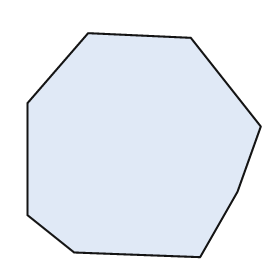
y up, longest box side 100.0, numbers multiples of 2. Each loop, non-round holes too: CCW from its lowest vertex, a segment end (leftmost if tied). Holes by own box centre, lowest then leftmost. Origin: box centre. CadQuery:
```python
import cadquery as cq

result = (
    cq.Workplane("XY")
    .moveTo(24.0, -48.0)
    .lineTo(40.0, -20.0)
    .lineTo(50.0, 8.0)
    .lineTo(20.0, 46.0)
    .lineTo(-24.0, 48.0)
    .lineTo(-50.0, 18.0)
    .lineTo(-50.0, -30.0)
    .lineTo(-30.0, -46.0)
    .close()
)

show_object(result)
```